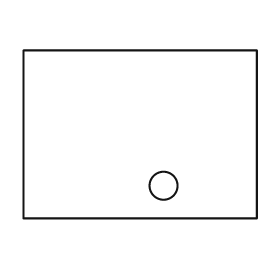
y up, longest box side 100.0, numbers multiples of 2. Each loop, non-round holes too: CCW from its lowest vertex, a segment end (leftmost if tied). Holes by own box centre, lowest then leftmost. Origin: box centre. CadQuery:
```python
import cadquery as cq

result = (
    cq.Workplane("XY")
    .moveTo(-50.0, -36.0)
    .lineTo(50.0, -36.0)
    .lineTo(50.0, 36.0)
    .lineTo(-50.0, 36.0)
    .close()
    .moveTo(10.0, -22.0)
    .circle(6.0)
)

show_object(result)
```